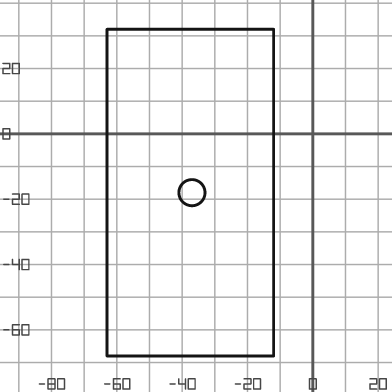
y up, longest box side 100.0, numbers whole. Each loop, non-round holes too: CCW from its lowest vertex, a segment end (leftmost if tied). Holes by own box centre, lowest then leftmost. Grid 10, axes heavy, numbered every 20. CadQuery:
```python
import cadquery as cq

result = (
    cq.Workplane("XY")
    .moveTo(-63.0, -68.0)
    .lineTo(-12.0, -68.0)
    .lineTo(-12.0, 32.0)
    .lineTo(-63.0, 32.0)
    .close()
    .moveTo(-37.0, -18.0)
    .circle(4.0)
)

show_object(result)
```